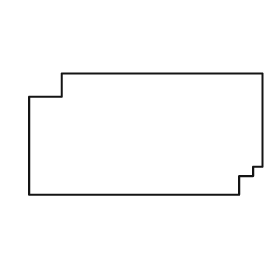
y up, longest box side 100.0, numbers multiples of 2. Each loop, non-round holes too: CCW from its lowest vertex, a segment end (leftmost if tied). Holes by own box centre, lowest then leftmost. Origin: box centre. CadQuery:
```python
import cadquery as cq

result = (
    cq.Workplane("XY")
    .moveTo(-50.0, -26.0)
    .lineTo(40.0, -26.0)
    .lineTo(40.0, -18.0)
    .lineTo(46.0, -18.0)
    .lineTo(46.0, -14.0)
    .lineTo(50.0, -14.0)
    .lineTo(50.0, 26.0)
    .lineTo(-36.0, 26.0)
    .lineTo(-36.0, 16.0)
    .lineTo(-50.0, 16.0)
    .close()
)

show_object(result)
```